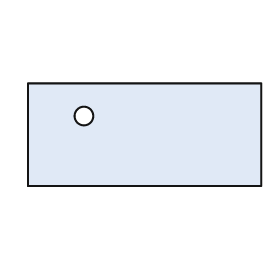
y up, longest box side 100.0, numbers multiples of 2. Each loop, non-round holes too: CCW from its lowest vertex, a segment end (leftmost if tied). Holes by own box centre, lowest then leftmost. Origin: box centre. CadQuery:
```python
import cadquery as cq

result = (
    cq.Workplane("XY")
    .moveTo(-50.0, -22.0)
    .lineTo(50.0, -22.0)
    .lineTo(50.0, 22.0)
    .lineTo(-50.0, 22.0)
    .close()
    .moveTo(-26.0, 8.0)
    .circle(4.0)
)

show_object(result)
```